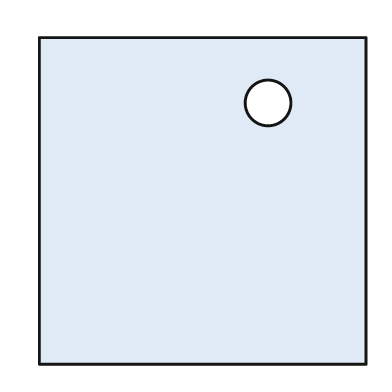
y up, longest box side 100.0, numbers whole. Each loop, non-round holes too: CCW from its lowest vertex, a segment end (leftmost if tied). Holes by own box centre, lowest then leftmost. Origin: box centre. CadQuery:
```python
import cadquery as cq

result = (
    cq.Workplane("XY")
    .moveTo(-50.0, -50.0)
    .lineTo(50.0, -50.0)
    .lineTo(50.0, 50.0)
    .lineTo(-50.0, 50.0)
    .close()
    .moveTo(20.0, 30.0)
    .circle(7.0)
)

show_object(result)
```